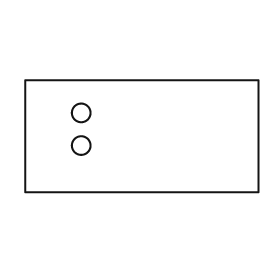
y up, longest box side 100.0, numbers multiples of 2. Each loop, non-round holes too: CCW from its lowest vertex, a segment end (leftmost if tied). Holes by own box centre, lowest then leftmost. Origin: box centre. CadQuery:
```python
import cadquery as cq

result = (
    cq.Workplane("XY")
    .moveTo(-50.0, -24.0)
    .lineTo(50.0, -24.0)
    .lineTo(50.0, 24.0)
    .lineTo(-50.0, 24.0)
    .close()
    .moveTo(-26.0, -4.0)
    .circle(4.0)
    .moveTo(-26.0, 10.0)
    .circle(4.0)
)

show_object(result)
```